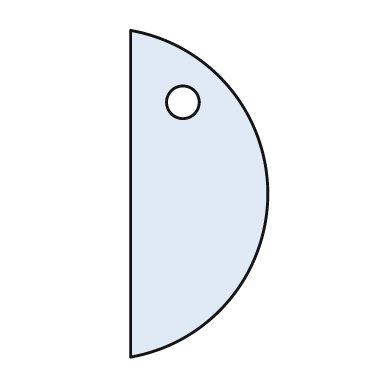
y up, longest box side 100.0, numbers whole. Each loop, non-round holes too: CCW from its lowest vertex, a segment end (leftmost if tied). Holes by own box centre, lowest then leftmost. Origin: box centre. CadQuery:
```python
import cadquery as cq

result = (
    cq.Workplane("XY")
    .moveTo(-21.0, -50.0)
    .threePointArc((21.0, 0.0), (-21.0, 50.0))
    .close()
    .moveTo(-5.0, 28.0)
    .circle(5.0)
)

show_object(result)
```